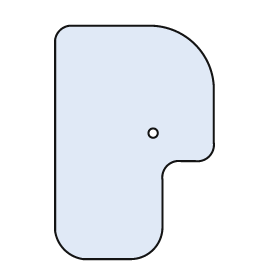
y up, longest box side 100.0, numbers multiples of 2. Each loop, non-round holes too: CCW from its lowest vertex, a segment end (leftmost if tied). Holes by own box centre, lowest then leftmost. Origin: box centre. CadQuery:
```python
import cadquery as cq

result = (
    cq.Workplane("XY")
    .moveTo(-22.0, -50.0)
    .lineTo(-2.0, -50.0)
    .threePointArc((8.0, -46.0), (12.0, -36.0))
    .lineTo(12.0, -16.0)
    .threePointArc((14.0, -10.0), (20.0, -8.0))
    .lineTo(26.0, -8.0)
    .threePointArc((32.0, -6.0), (34.0, 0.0))
    .lineTo(34.0, 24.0)
    .threePointArc((26.0, 42.0), (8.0, 50.0))
    .lineTo(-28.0, 50.0)
    .threePointArc((-32.0, 48.0), (-34.0, 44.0))
    .lineTo(-34.0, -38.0)
    .threePointArc((-30.0, -46.0), (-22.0, -50.0))
    .close()
    .moveTo(8.0, 4.0)
    .circle(2.0)
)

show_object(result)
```